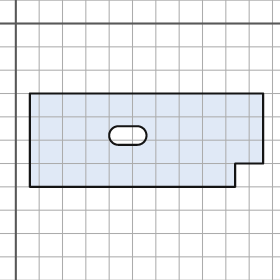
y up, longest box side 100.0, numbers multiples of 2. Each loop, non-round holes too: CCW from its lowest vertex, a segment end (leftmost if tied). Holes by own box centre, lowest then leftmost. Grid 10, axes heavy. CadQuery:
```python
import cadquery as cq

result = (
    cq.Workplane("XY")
    .moveTo(6.0, -70.0)
    .lineTo(94.0, -70.0)
    .lineTo(94.0, -60.0)
    .lineTo(106.0, -60.0)
    .lineTo(106.0, -30.0)
    .lineTo(6.0, -30.0)
    .close()
    .moveTo(44.0, -52.0)
    .lineTo(52.0, -52.0)
    .threePointArc((56.0, -48.0), (52.0, -44.0))
    .lineTo(44.0, -44.0)
    .threePointArc((40.0, -48.0), (44.0, -52.0))
    .close()
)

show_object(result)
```